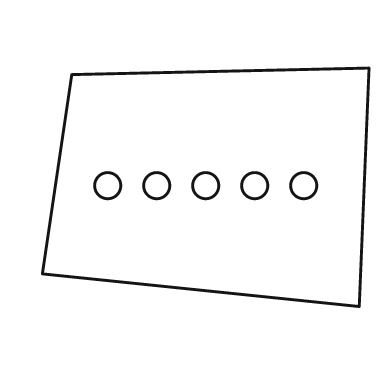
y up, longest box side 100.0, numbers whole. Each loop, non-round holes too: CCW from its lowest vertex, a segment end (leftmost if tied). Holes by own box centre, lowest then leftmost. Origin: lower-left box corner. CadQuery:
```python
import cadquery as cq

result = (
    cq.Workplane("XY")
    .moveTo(97.0, 0.0)
    .lineTo(100.0, 73.0)
    .lineTo(9.0, 71.0)
    .lineTo(0.0, 10.0)
    .close()
    .moveTo(20.0, 37.0)
    .circle(4.0)
    .moveTo(35.0, 37.0)
    .circle(4.0)
    .moveTo(50.0, 37.0)
    .circle(4.0)
    .moveTo(65.0, 37.0)
    .circle(4.0)
    .moveTo(80.0, 37.0)
    .circle(4.0)
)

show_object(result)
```